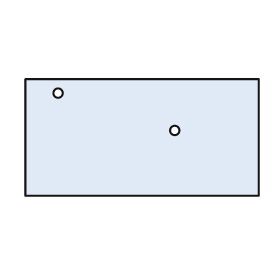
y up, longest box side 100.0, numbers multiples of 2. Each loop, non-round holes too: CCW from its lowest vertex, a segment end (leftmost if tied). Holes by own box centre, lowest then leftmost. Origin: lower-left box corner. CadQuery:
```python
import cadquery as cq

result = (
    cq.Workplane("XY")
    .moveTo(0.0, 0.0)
    .lineTo(100.0, 0.0)
    .lineTo(100.0, 50.0)
    .lineTo(0.0, 50.0)
    .close()
    .moveTo(64.0, 28.0)
    .circle(2.0)
    .moveTo(14.0, 44.0)
    .circle(2.0)
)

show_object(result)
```